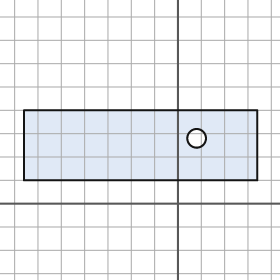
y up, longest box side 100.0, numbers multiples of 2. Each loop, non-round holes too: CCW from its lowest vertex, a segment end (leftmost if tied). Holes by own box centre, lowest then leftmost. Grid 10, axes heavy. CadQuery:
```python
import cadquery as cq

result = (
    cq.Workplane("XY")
    .moveTo(-66.0, 10.0)
    .lineTo(34.0, 10.0)
    .lineTo(34.0, 40.0)
    .lineTo(-66.0, 40.0)
    .close()
    .moveTo(8.0, 28.0)
    .circle(4.0)
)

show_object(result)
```